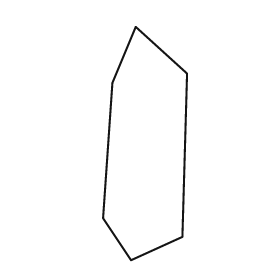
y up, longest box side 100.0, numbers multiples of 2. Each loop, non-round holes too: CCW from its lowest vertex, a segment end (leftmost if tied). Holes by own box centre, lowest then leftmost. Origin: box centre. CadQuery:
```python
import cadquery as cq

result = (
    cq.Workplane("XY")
    .moveTo(-6.0, -50.0)
    .lineTo(16.0, -40.0)
    .lineTo(18.0, 30.0)
    .lineTo(-4.0, 50.0)
    .lineTo(-14.0, 26.0)
    .lineTo(-18.0, -32.0)
    .close()
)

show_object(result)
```